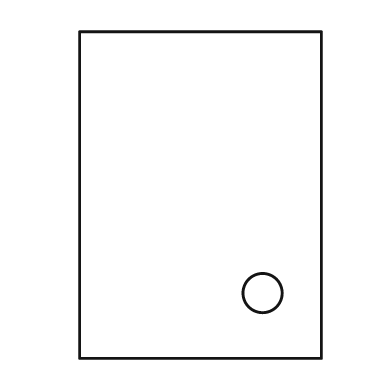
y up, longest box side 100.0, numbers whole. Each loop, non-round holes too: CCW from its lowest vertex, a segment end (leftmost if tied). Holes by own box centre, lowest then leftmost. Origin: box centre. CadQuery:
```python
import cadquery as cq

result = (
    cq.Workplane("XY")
    .moveTo(-37.0, -50.0)
    .lineTo(37.0, -50.0)
    .lineTo(37.0, 50.0)
    .lineTo(-37.0, 50.0)
    .close()
    .moveTo(19.0, -30.0)
    .circle(6.0)
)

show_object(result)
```